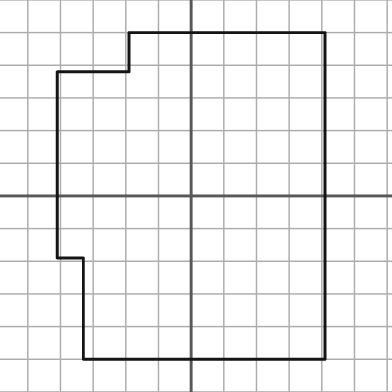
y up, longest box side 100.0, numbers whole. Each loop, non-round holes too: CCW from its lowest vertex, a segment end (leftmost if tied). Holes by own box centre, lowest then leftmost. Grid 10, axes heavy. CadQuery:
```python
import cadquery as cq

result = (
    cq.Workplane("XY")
    .moveTo(-33.0, -50.0)
    .lineTo(41.0, -50.0)
    .lineTo(41.0, 50.0)
    .lineTo(-19.0, 50.0)
    .lineTo(-19.0, 38.0)
    .lineTo(-41.0, 38.0)
    .lineTo(-41.0, -19.0)
    .lineTo(-33.0, -19.0)
    .close()
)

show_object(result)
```